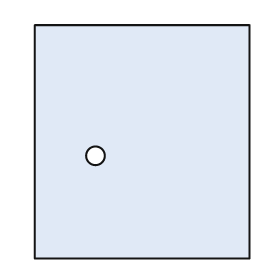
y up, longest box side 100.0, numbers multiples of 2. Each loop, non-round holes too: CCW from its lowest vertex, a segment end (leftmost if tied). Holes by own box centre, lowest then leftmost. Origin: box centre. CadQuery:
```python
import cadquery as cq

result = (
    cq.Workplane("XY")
    .moveTo(-46.0, -50.0)
    .lineTo(46.0, -50.0)
    .lineTo(46.0, 50.0)
    .lineTo(-46.0, 50.0)
    .close()
    .moveTo(-20.0, -6.0)
    .circle(4.0)
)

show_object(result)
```